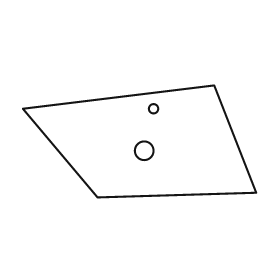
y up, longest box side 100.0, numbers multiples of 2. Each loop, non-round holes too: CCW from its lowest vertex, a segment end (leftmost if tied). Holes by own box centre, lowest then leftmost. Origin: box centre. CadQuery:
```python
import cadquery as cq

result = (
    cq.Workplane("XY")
    .moveTo(-18.0, -24.0)
    .lineTo(50.0, -22.0)
    .lineTo(32.0, 24.0)
    .lineTo(-50.0, 14.0)
    .close()
    .moveTo(2.0, -4.0)
    .circle(4.0)
    .moveTo(6.0, 14.0)
    .circle(2.0)
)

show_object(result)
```